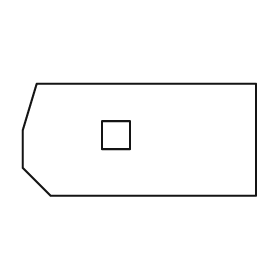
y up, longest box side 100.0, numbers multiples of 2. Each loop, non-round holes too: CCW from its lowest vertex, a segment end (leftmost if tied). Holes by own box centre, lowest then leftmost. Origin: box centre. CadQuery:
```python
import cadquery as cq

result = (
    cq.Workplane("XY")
    .moveTo(-38.0, -24.0)
    .lineTo(50.0, -24.0)
    .lineTo(50.0, 24.0)
    .lineTo(-44.0, 24.0)
    .lineTo(-50.0, 4.0)
    .lineTo(-50.0, -12.0)
    .close()
    .moveTo(-16.0, -4.0)
    .lineTo(-4.0, -4.0)
    .lineTo(-4.0, 8.0)
    .lineTo(-16.0, 8.0)
    .close()
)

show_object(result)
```